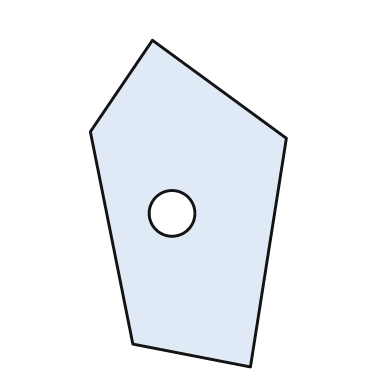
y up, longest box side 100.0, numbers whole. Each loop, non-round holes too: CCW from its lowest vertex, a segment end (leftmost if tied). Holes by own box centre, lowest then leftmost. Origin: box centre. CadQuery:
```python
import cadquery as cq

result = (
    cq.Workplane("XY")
    .moveTo(19.0, -50.0)
    .lineTo(30.0, 20.0)
    .lineTo(-11.0, 50.0)
    .lineTo(-30.0, 22.0)
    .lineTo(-17.0, -43.0)
    .close()
    .moveTo(-5.0, -3.0)
    .circle(7.0)
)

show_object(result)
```